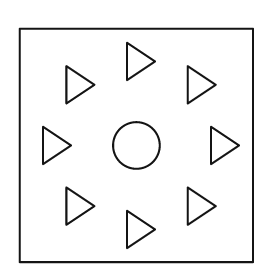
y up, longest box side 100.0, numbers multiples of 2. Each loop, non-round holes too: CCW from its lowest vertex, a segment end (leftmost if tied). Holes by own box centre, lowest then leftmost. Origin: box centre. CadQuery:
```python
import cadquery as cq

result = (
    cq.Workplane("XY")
    .moveTo(-50.0, -50.0)
    .lineTo(50.0, -50.0)
    .lineTo(50.0, 50.0)
    .lineTo(-50.0, 50.0)
    .close()
    .moveTo(-4.0, -44.0)
    .lineTo(8.0, -36.0)
    .lineTo(-4.0, -28.0)
    .close()
    .moveTo(-30.0, -34.0)
    .lineTo(-18.0, -26.0)
    .lineTo(-30.0, -18.0)
    .close()
    .moveTo(22.0, -34.0)
    .lineTo(34.0, -26.0)
    .lineTo(22.0, -18.0)
    .close()
    .moveTo(-40.0, -8.0)
    .lineTo(-28.0, 0.0)
    .lineTo(-40.0, 8.0)
    .close()
    .moveTo(0.0, 0.0)
    .circle(10.0)
    .moveTo(32.0, -8.0)
    .lineTo(44.0, 0.0)
    .lineTo(32.0, 8.0)
    .close()
    .moveTo(-30.0, 18.0)
    .lineTo(-18.0, 26.0)
    .lineTo(-30.0, 34.0)
    .close()
    .moveTo(22.0, 18.0)
    .lineTo(34.0, 26.0)
    .lineTo(22.0, 34.0)
    .close()
    .moveTo(-4.0, 28.0)
    .lineTo(8.0, 36.0)
    .lineTo(-4.0, 44.0)
    .close()
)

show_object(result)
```